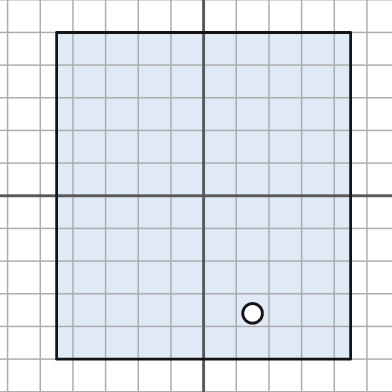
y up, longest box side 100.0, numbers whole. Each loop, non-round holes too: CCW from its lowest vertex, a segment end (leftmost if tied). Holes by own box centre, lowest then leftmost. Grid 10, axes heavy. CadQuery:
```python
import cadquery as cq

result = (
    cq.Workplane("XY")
    .moveTo(-45.0, -50.0)
    .lineTo(45.0, -50.0)
    .lineTo(45.0, 50.0)
    .lineTo(-45.0, 50.0)
    .close()
    .moveTo(15.0, -36.0)
    .circle(3.0)
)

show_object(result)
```